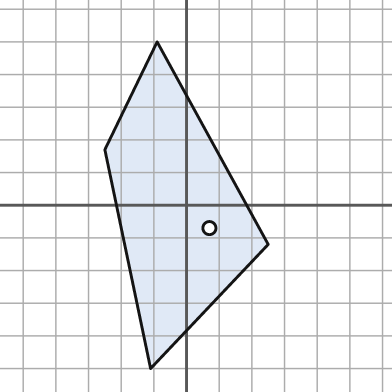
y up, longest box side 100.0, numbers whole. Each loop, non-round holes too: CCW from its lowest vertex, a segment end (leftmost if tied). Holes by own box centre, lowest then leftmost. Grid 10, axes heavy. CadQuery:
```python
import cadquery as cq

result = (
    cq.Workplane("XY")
    .moveTo(-11.0, -50.0)
    .lineTo(25.0, -12.0)
    .lineTo(-9.0, 50.0)
    .lineTo(-25.0, 17.0)
    .close()
    .moveTo(7.0, -7.0)
    .circle(2.0)
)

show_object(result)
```